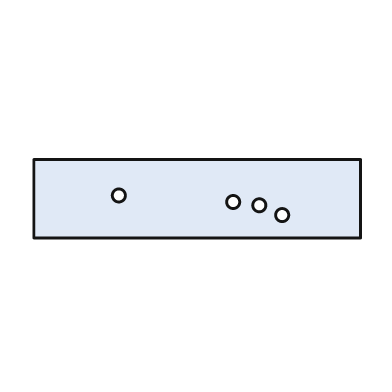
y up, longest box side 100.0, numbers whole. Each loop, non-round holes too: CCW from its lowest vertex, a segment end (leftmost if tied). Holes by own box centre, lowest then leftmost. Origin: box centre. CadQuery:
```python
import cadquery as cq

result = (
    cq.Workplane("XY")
    .moveTo(-50.0, -12.0)
    .lineTo(50.0, -12.0)
    .lineTo(50.0, 12.0)
    .lineTo(-50.0, 12.0)
    .close()
    .moveTo(26.0, -5.0)
    .circle(2.0)
    .moveTo(19.0, -2.0)
    .circle(2.0)
    .moveTo(11.0, -1.0)
    .circle(2.0)
    .moveTo(-24.0, 1.0)
    .circle(2.0)
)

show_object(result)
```